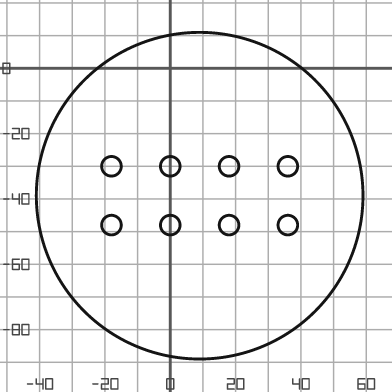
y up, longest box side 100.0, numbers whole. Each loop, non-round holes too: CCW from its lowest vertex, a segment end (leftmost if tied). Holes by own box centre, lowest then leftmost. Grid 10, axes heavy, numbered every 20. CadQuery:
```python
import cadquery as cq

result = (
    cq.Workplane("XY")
    .moveTo(9.0, -39.0)
    .circle(50.0)
    .moveTo(-18.0, -48.0)
    .circle(3.0)
    .moveTo(0.0, -48.0)
    .circle(3.0)
    .moveTo(18.0, -48.0)
    .circle(3.0)
    .moveTo(36.0, -48.0)
    .circle(3.0)
    .moveTo(-18.0, -30.0)
    .circle(3.0)
    .moveTo(0.0, -30.0)
    .circle(3.0)
    .moveTo(18.0, -30.0)
    .circle(3.0)
    .moveTo(36.0, -30.0)
    .circle(3.0)
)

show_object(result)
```